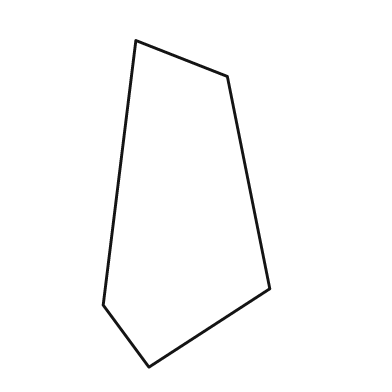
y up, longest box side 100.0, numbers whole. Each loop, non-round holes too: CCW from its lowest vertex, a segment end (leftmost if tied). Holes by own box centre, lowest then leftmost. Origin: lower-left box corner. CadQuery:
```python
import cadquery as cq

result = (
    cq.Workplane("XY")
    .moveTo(14.0, 0.0)
    .lineTo(51.0, 24.0)
    .lineTo(38.0, 89.0)
    .lineTo(10.0, 100.0)
    .lineTo(0.0, 19.0)
    .close()
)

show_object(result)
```